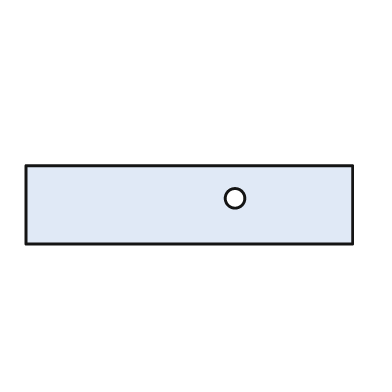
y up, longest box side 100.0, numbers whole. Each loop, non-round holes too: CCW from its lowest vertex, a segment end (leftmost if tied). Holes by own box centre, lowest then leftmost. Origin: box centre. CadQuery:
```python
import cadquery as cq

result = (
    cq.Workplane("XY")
    .moveTo(-50.0, -12.0)
    .lineTo(50.0, -12.0)
    .lineTo(50.0, 12.0)
    .lineTo(-50.0, 12.0)
    .close()
    .moveTo(14.0, 2.0)
    .circle(3.0)
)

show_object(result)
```